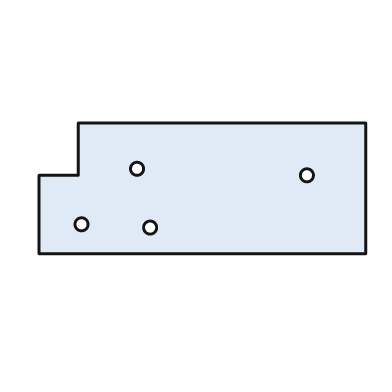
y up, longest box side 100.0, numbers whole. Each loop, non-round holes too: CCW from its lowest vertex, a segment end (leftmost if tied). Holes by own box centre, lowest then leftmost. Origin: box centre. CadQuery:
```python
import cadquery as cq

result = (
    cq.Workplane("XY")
    .moveTo(-50.0, -20.0)
    .lineTo(50.0, -20.0)
    .lineTo(50.0, 20.0)
    .lineTo(-38.0, 20.0)
    .lineTo(-38.0, 4.0)
    .lineTo(-50.0, 4.0)
    .close()
    .moveTo(-16.0, -12.0)
    .circle(2.0)
    .moveTo(-37.0, -11.0)
    .circle(2.0)
    .moveTo(32.0, 4.0)
    .circle(2.0)
    .moveTo(-20.0, 6.0)
    .circle(2.0)
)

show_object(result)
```